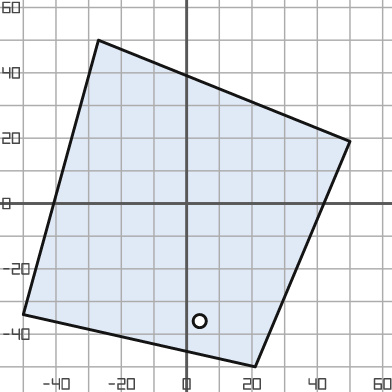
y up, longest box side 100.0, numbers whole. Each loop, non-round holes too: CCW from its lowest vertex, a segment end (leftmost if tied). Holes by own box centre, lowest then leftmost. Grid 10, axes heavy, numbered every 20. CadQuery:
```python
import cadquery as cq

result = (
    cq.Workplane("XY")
    .moveTo(21.0, -50.0)
    .lineTo(50.0, 19.0)
    .lineTo(-27.0, 50.0)
    .lineTo(-50.0, -34.0)
    .close()
    .moveTo(4.0, -36.0)
    .circle(2.0)
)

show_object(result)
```